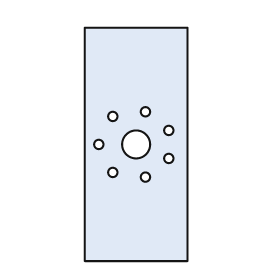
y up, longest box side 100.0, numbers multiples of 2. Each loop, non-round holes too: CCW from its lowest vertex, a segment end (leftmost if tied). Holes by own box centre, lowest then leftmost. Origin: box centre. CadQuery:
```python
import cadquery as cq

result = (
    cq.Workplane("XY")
    .moveTo(-22.0, -50.0)
    .lineTo(22.0, -50.0)
    .lineTo(22.0, 50.0)
    .lineTo(-22.0, 50.0)
    .close()
    .moveTo(4.0, -14.0)
    .circle(2.0)
    .moveTo(-10.0, -12.0)
    .circle(2.0)
    .moveTo(14.0, -6.0)
    .circle(2.0)
    .moveTo(-16.0, 0.0)
    .circle(2.0)
    .moveTo(0.0, 0.0)
    .circle(6.0)
    .moveTo(14.0, 6.0)
    .circle(2.0)
    .moveTo(-10.0, 12.0)
    .circle(2.0)
    .moveTo(4.0, 14.0)
    .circle(2.0)
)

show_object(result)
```